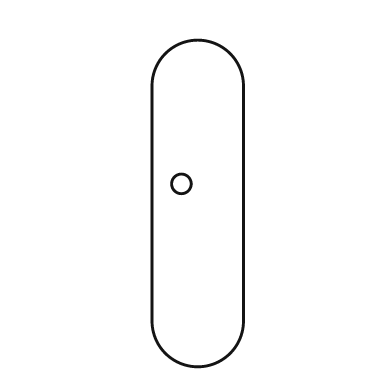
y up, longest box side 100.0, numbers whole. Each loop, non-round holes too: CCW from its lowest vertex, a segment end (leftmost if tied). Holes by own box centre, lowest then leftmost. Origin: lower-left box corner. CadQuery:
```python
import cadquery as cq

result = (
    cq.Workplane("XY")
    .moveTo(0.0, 14.0)
    .threePointArc((14.0, 0.0), (28.0, 14.0))
    .lineTo(28.0, 86.0)
    .threePointArc((14.0, 100.0), (0.0, 86.0))
    .close()
    .moveTo(9.0, 56.0)
    .circle(3.0)
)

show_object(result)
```